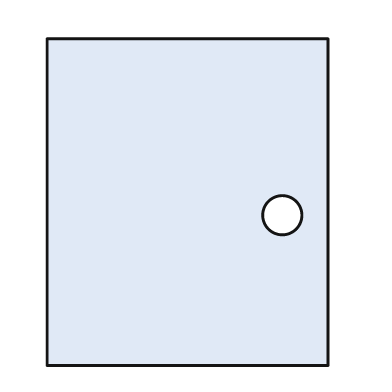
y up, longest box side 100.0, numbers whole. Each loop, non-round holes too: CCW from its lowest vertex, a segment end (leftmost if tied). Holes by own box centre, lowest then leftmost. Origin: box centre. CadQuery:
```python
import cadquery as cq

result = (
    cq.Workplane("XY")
    .moveTo(-43.0, -50.0)
    .lineTo(43.0, -50.0)
    .lineTo(43.0, 50.0)
    .lineTo(-43.0, 50.0)
    .close()
    .moveTo(29.0, -4.0)
    .circle(6.0)
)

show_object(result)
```